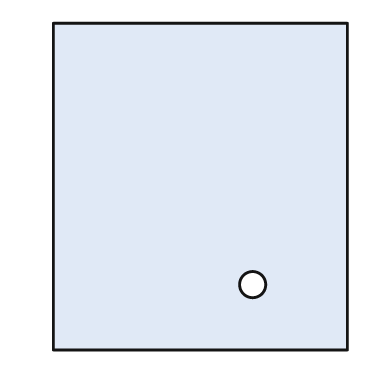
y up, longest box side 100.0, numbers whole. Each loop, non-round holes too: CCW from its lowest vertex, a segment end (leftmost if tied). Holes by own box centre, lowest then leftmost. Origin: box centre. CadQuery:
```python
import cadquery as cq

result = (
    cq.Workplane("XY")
    .moveTo(-45.0, -50.0)
    .lineTo(45.0, -50.0)
    .lineTo(45.0, 50.0)
    .lineTo(-45.0, 50.0)
    .close()
    .moveTo(16.0, -30.0)
    .circle(4.0)
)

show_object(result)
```